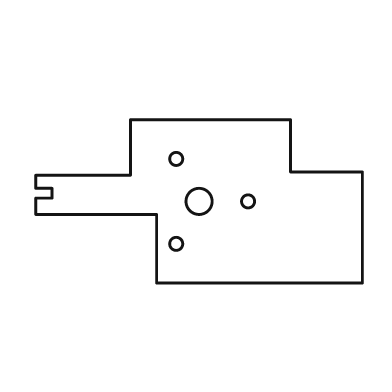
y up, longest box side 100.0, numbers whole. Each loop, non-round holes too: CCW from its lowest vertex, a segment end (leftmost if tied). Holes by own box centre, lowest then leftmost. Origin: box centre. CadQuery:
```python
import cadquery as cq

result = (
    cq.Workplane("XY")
    .moveTo(-13.0, -25.0)
    .lineTo(50.0, -25.0)
    .lineTo(50.0, 9.0)
    .lineTo(28.0, 9.0)
    .lineTo(28.0, 25.0)
    .lineTo(-21.0, 25.0)
    .lineTo(-21.0, 8.0)
    .lineTo(-50.0, 8.0)
    .lineTo(-50.0, 4.0)
    .lineTo(-45.0, 4.0)
    .lineTo(-45.0, 1.0)
    .lineTo(-50.0, 1.0)
    .lineTo(-50.0, -4.0)
    .lineTo(-13.0, -4.0)
    .close()
    .moveTo(-7.0, -13.0)
    .circle(2.0)
    .moveTo(0.0, 0.0)
    .circle(4.0)
    .moveTo(15.0, 0.0)
    .circle(2.0)
    .moveTo(-7.0, 13.0)
    .circle(2.0)
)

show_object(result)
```